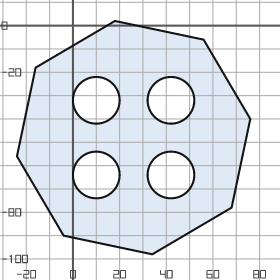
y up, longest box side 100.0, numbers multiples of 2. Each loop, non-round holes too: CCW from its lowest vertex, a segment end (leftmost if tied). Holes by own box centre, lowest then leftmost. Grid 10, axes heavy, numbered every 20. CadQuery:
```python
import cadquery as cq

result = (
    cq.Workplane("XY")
    .moveTo(34.0, -98.0)
    .lineTo(68.0, -78.0)
    .lineTo(76.0, -40.0)
    .lineTo(56.0, -6.0)
    .lineTo(18.0, 2.0)
    .lineTo(-16.0, -18.0)
    .lineTo(-24.0, -56.0)
    .lineTo(-4.0, -90.0)
    .close()
    .moveTo(10.0, -64.0)
    .circle(10.0)
    .moveTo(42.0, -64.0)
    .circle(10.0)
    .moveTo(10.0, -32.0)
    .circle(10.0)
    .moveTo(42.0, -32.0)
    .circle(10.0)
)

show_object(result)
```